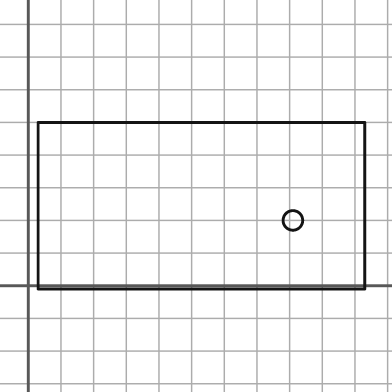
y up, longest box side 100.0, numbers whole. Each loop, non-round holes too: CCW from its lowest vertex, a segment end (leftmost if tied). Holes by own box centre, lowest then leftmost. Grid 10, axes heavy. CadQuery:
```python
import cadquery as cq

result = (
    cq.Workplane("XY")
    .moveTo(3.0, -1.0)
    .lineTo(103.0, -1.0)
    .lineTo(103.0, 50.0)
    .lineTo(3.0, 50.0)
    .close()
    .moveTo(81.0, 20.0)
    .circle(3.0)
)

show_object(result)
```